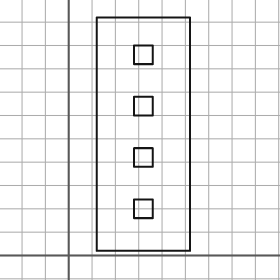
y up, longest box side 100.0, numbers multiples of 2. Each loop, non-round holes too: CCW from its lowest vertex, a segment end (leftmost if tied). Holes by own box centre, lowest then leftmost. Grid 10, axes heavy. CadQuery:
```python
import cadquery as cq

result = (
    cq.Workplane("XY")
    .moveTo(12.0, 2.0)
    .lineTo(52.0, 2.0)
    .lineTo(52.0, 102.0)
    .lineTo(12.0, 102.0)
    .close()
    .moveTo(28.0, 16.0)
    .lineTo(36.0, 16.0)
    .lineTo(36.0, 24.0)
    .lineTo(28.0, 24.0)
    .close()
    .moveTo(28.0, 38.0)
    .lineTo(36.0, 38.0)
    .lineTo(36.0, 46.0)
    .lineTo(28.0, 46.0)
    .close()
    .moveTo(28.0, 60.0)
    .lineTo(36.0, 60.0)
    .lineTo(36.0, 68.0)
    .lineTo(28.0, 68.0)
    .close()
    .moveTo(28.0, 82.0)
    .lineTo(36.0, 82.0)
    .lineTo(36.0, 90.0)
    .lineTo(28.0, 90.0)
    .close()
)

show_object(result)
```